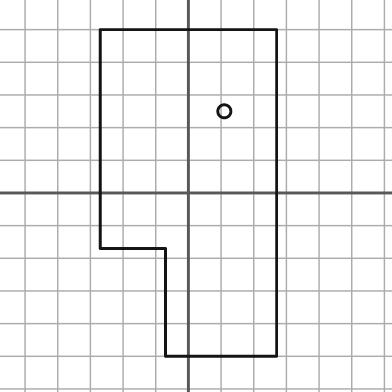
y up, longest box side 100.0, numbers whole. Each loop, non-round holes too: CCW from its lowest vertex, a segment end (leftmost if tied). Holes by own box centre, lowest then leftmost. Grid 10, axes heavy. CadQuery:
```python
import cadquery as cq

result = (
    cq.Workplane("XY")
    .moveTo(-7.0, -50.0)
    .lineTo(27.0, -50.0)
    .lineTo(27.0, 50.0)
    .lineTo(-27.0, 50.0)
    .lineTo(-27.0, -17.0)
    .lineTo(-7.0, -17.0)
    .close()
    .moveTo(11.0, 25.0)
    .circle(2.0)
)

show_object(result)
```